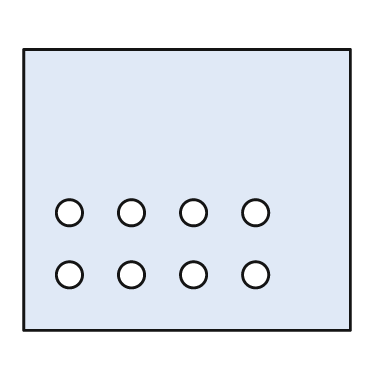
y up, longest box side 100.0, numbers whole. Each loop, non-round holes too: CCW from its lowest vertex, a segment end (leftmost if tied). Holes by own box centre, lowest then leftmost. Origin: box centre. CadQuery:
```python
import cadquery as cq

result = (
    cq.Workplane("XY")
    .moveTo(-50.0, -43.0)
    .lineTo(50.0, -43.0)
    .lineTo(50.0, 43.0)
    .lineTo(-50.0, 43.0)
    .close()
    .moveTo(-36.0, -26.0)
    .circle(4.0)
    .moveTo(-17.0, -26.0)
    .circle(4.0)
    .moveTo(2.0, -26.0)
    .circle(4.0)
    .moveTo(21.0, -26.0)
    .circle(4.0)
    .moveTo(-36.0, -7.0)
    .circle(4.0)
    .moveTo(-17.0, -7.0)
    .circle(4.0)
    .moveTo(2.0, -7.0)
    .circle(4.0)
    .moveTo(21.0, -7.0)
    .circle(4.0)
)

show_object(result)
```